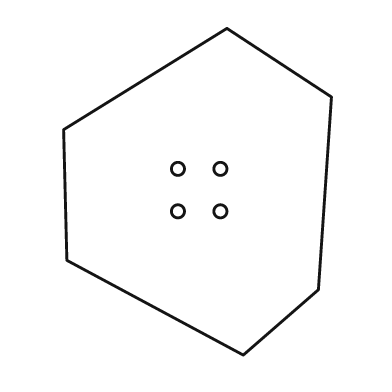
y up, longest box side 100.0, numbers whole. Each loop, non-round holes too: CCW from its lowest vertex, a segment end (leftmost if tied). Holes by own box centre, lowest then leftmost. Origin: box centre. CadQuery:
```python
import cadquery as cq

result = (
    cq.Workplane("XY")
    .moveTo(14.0, -50.0)
    .lineTo(37.0, -30.0)
    .lineTo(41.0, 29.0)
    .lineTo(9.0, 50.0)
    .lineTo(-41.0, 19.0)
    .lineTo(-40.0, -21.0)
    .close()
    .moveTo(-6.0, -6.0)
    .circle(2.0)
    .moveTo(7.0, -6.0)
    .circle(2.0)
    .moveTo(-6.0, 7.0)
    .circle(2.0)
    .moveTo(7.0, 7.0)
    .circle(2.0)
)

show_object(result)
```